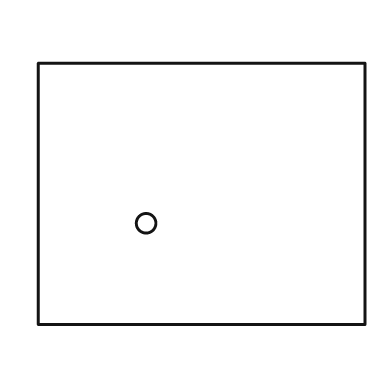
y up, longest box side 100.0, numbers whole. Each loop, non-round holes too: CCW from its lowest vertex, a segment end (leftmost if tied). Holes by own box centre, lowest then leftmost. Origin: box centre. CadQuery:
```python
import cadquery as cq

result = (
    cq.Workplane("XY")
    .moveTo(-50.0, -40.0)
    .lineTo(50.0, -40.0)
    .lineTo(50.0, 40.0)
    .lineTo(-50.0, 40.0)
    .close()
    .moveTo(-17.0, -9.0)
    .circle(3.0)
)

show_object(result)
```